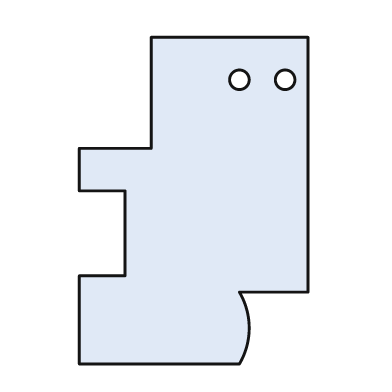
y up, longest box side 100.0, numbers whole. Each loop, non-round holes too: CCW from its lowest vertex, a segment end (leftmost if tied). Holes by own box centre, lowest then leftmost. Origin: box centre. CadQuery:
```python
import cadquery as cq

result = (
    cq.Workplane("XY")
    .moveTo(-35.0, -50.0)
    .lineTo(14.0, -50.0)
    .threePointArc((17.0, -39.0), (14.0, -28.0))
    .lineTo(35.0, -28.0)
    .lineTo(35.0, 50.0)
    .lineTo(-13.0, 50.0)
    .lineTo(-13.0, 16.0)
    .lineTo(-35.0, 16.0)
    .lineTo(-35.0, 3.0)
    .lineTo(-21.0, 3.0)
    .lineTo(-21.0, -23.0)
    .lineTo(-35.0, -23.0)
    .close()
    .moveTo(14.0, 37.0)
    .circle(3.0)
    .moveTo(28.0, 37.0)
    .circle(3.0)
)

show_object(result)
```